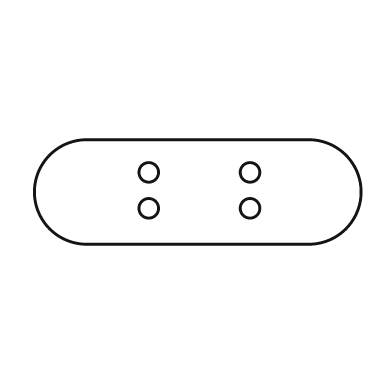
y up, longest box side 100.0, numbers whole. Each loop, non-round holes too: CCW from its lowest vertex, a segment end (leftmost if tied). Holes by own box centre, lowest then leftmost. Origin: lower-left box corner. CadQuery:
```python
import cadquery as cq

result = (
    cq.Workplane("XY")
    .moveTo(16.0, 0.0)
    .lineTo(84.0, 0.0)
    .threePointArc((100.0, 16.0), (84.0, 32.0))
    .lineTo(16.0, 32.0)
    .threePointArc((0.0, 16.0), (16.0, 0.0))
    .close()
    .moveTo(35.0, 11.0)
    .circle(3.0)
    .moveTo(66.0, 11.0)
    .circle(3.0)
    .moveTo(35.0, 22.0)
    .circle(3.0)
    .moveTo(66.0, 22.0)
    .circle(3.0)
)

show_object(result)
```